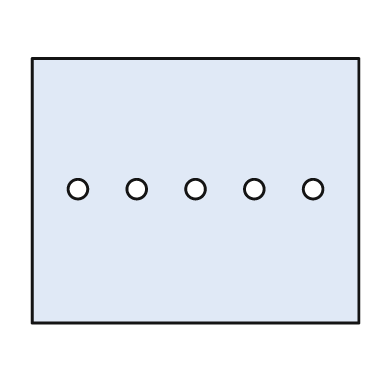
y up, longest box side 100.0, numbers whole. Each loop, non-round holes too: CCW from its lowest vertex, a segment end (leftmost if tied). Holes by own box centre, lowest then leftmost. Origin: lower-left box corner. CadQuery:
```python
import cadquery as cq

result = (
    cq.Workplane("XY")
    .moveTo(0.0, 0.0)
    .lineTo(100.0, 0.0)
    .lineTo(100.0, 81.0)
    .lineTo(0.0, 81.0)
    .close()
    .moveTo(14.0, 41.0)
    .circle(3.0)
    .moveTo(32.0, 41.0)
    .circle(3.0)
    .moveTo(50.0, 41.0)
    .circle(3.0)
    .moveTo(68.0, 41.0)
    .circle(3.0)
    .moveTo(86.0, 41.0)
    .circle(3.0)
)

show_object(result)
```